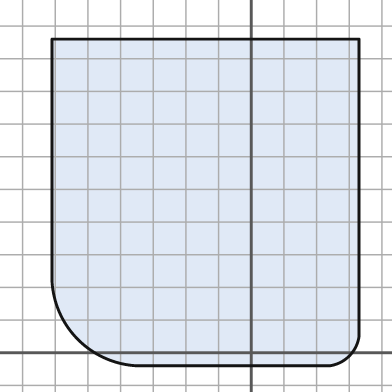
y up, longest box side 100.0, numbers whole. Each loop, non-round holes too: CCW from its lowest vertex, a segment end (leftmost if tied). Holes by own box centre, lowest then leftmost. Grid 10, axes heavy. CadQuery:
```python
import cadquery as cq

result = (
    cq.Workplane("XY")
    .moveTo(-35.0, -4.0)
    .lineTo(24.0, -4.0)
    .threePointArc((30.0, -1.0), (33.0, 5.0))
    .lineTo(33.0, 96.0)
    .lineTo(-61.0, 96.0)
    .lineTo(-61.0, 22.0)
    .threePointArc((-53.0, 4.0), (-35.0, -4.0))
    .close()
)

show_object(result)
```